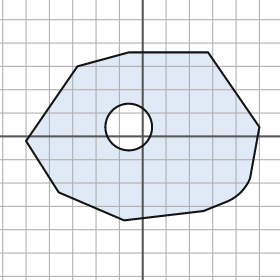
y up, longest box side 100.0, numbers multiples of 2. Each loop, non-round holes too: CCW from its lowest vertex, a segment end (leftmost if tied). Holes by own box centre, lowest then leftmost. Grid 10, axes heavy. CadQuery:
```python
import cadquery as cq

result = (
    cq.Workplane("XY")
    .moveTo(-8.0, -36.0)
    .lineTo(26.0, -32.0)
    .lineTo(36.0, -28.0)
    .threePointArc((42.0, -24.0), (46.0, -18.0))
    .lineTo(50.0, 4.0)
    .lineTo(28.0, 36.0)
    .lineTo(-6.0, 36.0)
    .lineTo(-28.0, 30.0)
    .lineTo(-50.0, -2.0)
    .lineTo(-36.0, -24.0)
    .close()
    .moveTo(-6.0, 4.0)
    .circle(10.0)
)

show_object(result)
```